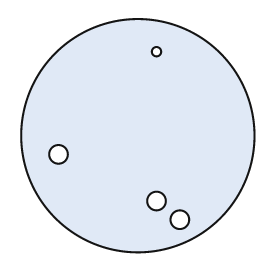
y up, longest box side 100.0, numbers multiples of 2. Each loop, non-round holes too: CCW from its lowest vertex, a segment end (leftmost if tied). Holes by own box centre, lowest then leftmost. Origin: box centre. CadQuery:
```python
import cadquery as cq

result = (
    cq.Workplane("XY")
    .moveTo(0.0, 0.0)
    .circle(50.0)
    .moveTo(18.0, -36.0)
    .circle(4.0)
    .moveTo(8.0, -28.0)
    .circle(4.0)
    .moveTo(-34.0, -8.0)
    .circle(4.0)
    .moveTo(8.0, 36.0)
    .circle(2.0)
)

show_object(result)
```